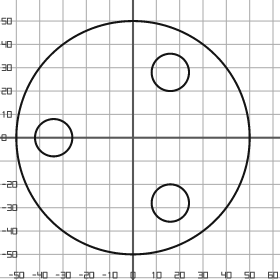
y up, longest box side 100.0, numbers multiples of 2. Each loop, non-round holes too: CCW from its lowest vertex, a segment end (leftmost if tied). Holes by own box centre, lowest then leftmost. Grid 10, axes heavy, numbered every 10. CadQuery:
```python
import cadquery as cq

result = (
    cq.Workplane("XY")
    .moveTo(0.0, 0.0)
    .circle(50.0)
    .moveTo(16.0, -28.0)
    .circle(8.0)
    .moveTo(-34.0, 0.0)
    .circle(8.0)
    .moveTo(16.0, 28.0)
    .circle(8.0)
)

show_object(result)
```